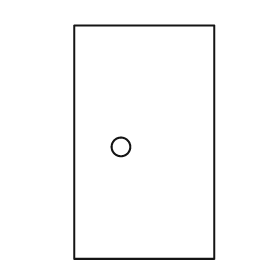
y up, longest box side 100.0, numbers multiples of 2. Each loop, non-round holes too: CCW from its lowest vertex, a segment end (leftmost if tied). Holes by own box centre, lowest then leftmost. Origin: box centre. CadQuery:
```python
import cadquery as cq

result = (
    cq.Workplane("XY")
    .moveTo(-30.0, -50.0)
    .lineTo(30.0, -50.0)
    .lineTo(30.0, 50.0)
    .lineTo(-30.0, 50.0)
    .close()
    .moveTo(-10.0, -2.0)
    .circle(4.0)
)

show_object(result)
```